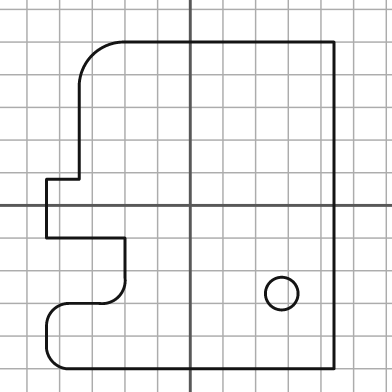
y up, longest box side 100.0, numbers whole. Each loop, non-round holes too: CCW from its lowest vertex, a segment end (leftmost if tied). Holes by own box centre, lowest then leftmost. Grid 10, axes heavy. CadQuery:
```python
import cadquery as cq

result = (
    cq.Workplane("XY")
    .moveTo(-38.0, -50.0)
    .lineTo(44.0, -50.0)
    .lineTo(44.0, 50.0)
    .lineTo(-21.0, 50.0)
    .threePointArc((-30.0, 46.0), (-34.0, 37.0))
    .lineTo(-34.0, 8.0)
    .lineTo(-44.0, 8.0)
    .lineTo(-44.0, -10.0)
    .lineTo(-20.0, -10.0)
    .lineTo(-20.0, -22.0)
    .threePointArc((-22.0, -28.0), (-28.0, -30.0))
    .lineTo(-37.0, -30.0)
    .threePointArc((-42.0, -32.0), (-44.0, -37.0))
    .lineTo(-44.0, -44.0)
    .threePointArc((-42.0, -48.0), (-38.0, -50.0))
    .close()
    .moveTo(28.0, -27.0)
    .circle(5.0)
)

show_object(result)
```